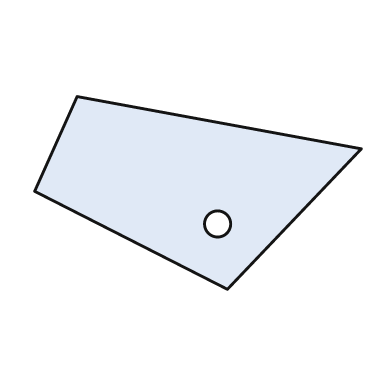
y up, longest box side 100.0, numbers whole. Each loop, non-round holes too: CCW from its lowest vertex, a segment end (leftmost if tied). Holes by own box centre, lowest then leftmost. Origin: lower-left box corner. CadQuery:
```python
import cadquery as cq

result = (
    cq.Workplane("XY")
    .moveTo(59.0, 0.0)
    .lineTo(100.0, 43.0)
    .lineTo(13.0, 59.0)
    .lineTo(0.0, 30.0)
    .close()
    .moveTo(56.0, 20.0)
    .circle(4.0)
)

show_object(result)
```